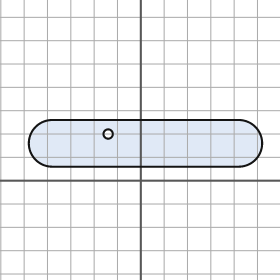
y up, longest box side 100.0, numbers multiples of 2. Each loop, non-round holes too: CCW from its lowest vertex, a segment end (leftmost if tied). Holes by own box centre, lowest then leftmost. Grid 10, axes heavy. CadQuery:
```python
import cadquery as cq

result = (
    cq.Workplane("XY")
    .moveTo(-38.0, 6.0)
    .lineTo(42.0, 6.0)
    .threePointArc((52.0, 16.0), (42.0, 26.0))
    .lineTo(-38.0, 26.0)
    .threePointArc((-48.0, 16.0), (-38.0, 6.0))
    .close()
    .moveTo(-14.0, 20.0)
    .circle(2.0)
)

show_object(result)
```